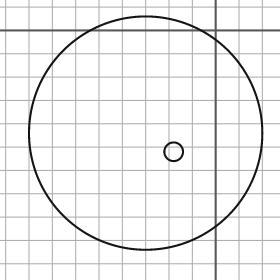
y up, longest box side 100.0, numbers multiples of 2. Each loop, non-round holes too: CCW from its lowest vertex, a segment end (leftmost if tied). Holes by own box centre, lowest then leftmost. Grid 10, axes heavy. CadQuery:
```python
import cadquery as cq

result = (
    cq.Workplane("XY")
    .moveTo(-30.0, -44.0)
    .circle(50.0)
    .moveTo(-18.0, -52.0)
    .circle(4.0)
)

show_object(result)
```